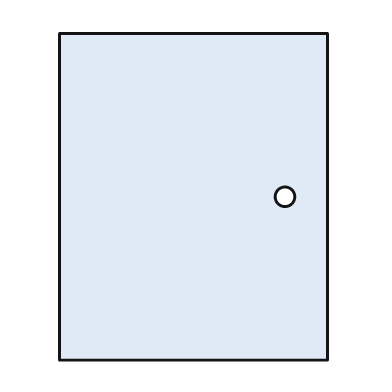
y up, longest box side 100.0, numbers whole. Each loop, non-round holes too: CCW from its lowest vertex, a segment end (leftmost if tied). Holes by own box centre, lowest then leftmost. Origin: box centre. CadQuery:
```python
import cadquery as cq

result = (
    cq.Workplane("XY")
    .moveTo(-41.0, -50.0)
    .lineTo(41.0, -50.0)
    .lineTo(41.0, 50.0)
    .lineTo(-41.0, 50.0)
    .close()
    .moveTo(28.0, 0.0)
    .circle(3.0)
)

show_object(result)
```